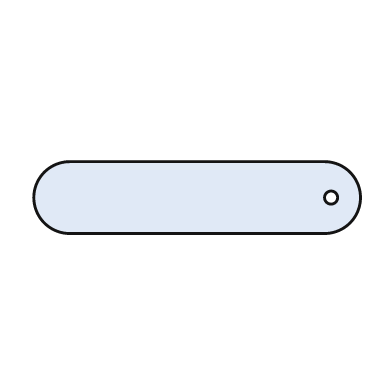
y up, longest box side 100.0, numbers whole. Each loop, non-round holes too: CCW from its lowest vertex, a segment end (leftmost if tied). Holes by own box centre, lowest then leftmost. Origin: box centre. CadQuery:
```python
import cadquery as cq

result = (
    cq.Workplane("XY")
    .moveTo(-39.0, -11.0)
    .lineTo(39.0, -11.0)
    .threePointArc((50.0, 0.0), (39.0, 11.0))
    .lineTo(-39.0, 11.0)
    .threePointArc((-50.0, 0.0), (-39.0, -11.0))
    .close()
    .moveTo(41.0, 0.0)
    .circle(2.0)
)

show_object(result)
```